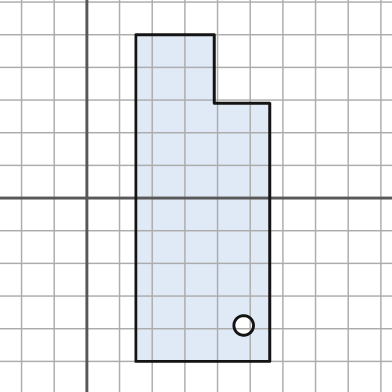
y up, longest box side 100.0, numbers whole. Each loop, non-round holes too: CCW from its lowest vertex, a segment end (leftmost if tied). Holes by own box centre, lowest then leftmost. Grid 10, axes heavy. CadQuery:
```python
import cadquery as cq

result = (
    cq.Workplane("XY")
    .moveTo(15.0, -50.0)
    .lineTo(56.0, -50.0)
    .lineTo(56.0, 29.0)
    .lineTo(39.0, 29.0)
    .lineTo(39.0, 50.0)
    .lineTo(15.0, 50.0)
    .close()
    .moveTo(48.0, -39.0)
    .circle(3.0)
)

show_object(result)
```